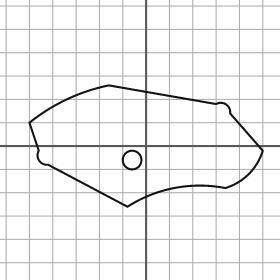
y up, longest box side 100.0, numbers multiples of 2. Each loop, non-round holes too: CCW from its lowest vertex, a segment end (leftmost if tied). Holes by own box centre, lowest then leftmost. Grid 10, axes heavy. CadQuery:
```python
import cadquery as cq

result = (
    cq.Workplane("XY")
    .moveTo(-8.0, -26.0)
    .threePointArc((12.0, -18.0), (34.0, -18.0))
    .threePointArc((44.0, -12.0), (50.0, -2.0))
    .lineTo(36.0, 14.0)
    .threePointArc((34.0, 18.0), (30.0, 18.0))
    .lineTo(-16.0, 26.0)
    .threePointArc((-34.0, 20.0), (-50.0, 10.0))
    .lineTo(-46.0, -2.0)
    .threePointArc((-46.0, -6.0), (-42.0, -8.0))
    .close()
    .moveTo(-6.0, -6.0)
    .circle(4.0)
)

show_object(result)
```